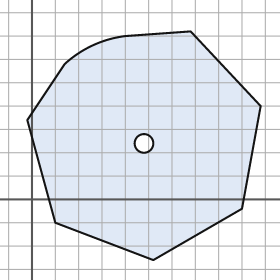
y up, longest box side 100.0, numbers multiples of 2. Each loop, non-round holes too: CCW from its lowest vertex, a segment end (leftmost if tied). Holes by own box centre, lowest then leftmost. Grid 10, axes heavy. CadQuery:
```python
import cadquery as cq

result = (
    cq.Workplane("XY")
    .moveTo(52.0, -26.0)
    .lineTo(90.0, -4.0)
    .lineTo(98.0, 40.0)
    .lineTo(68.0, 72.0)
    .lineTo(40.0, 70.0)
    .threePointArc((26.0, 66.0), (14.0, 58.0))
    .lineTo(-2.0, 34.0)
    .lineTo(10.0, -10.0)
    .close()
    .moveTo(48.0, 24.0)
    .circle(4.0)
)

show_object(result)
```